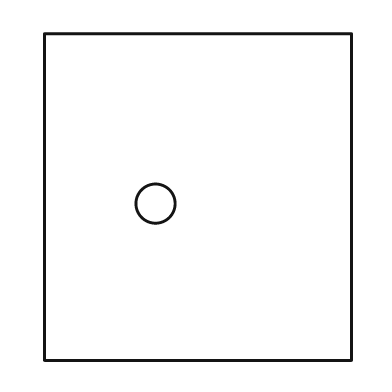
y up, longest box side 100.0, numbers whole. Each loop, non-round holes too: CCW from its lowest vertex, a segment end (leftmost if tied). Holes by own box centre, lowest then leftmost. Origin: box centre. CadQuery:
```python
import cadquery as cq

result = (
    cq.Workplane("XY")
    .moveTo(-47.0, -50.0)
    .lineTo(47.0, -50.0)
    .lineTo(47.0, 50.0)
    .lineTo(-47.0, 50.0)
    .close()
    .moveTo(-13.0, -2.0)
    .circle(6.0)
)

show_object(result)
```